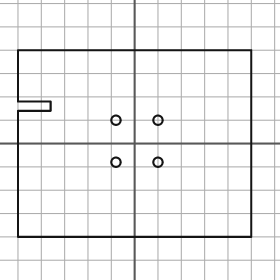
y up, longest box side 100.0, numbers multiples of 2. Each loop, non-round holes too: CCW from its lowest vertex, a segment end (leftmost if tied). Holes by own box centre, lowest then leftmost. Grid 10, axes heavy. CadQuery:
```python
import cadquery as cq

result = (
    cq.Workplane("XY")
    .moveTo(-50.0, -40.0)
    .lineTo(50.0, -40.0)
    .lineTo(50.0, 40.0)
    .lineTo(-50.0, 40.0)
    .lineTo(-50.0, 18.0)
    .lineTo(-36.0, 18.0)
    .lineTo(-36.0, 14.0)
    .lineTo(-50.0, 14.0)
    .close()
    .moveTo(-8.0, -8.0)
    .circle(2.0)
    .moveTo(10.0, -8.0)
    .circle(2.0)
    .moveTo(-8.0, 10.0)
    .circle(2.0)
    .moveTo(10.0, 10.0)
    .circle(2.0)
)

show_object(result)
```